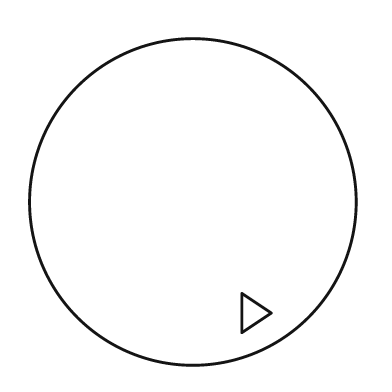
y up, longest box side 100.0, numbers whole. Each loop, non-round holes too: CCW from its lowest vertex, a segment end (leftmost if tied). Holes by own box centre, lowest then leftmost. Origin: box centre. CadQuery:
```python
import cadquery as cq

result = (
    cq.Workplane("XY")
    .moveTo(0.0, 0.0)
    .circle(50.0)
    .moveTo(15.0, -40.0)
    .lineTo(24.0, -34.0)
    .lineTo(15.0, -28.0)
    .close()
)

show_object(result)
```